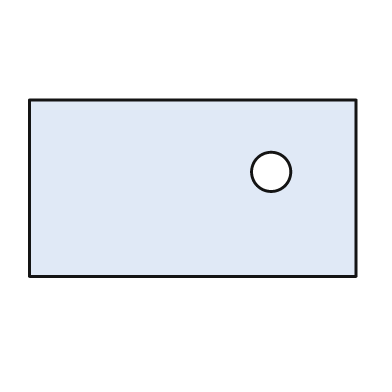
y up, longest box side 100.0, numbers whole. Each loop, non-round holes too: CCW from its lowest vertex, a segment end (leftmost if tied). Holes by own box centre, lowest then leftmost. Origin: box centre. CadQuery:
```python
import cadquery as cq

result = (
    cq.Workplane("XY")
    .moveTo(-50.0, -27.0)
    .lineTo(50.0, -27.0)
    .lineTo(50.0, 27.0)
    .lineTo(-50.0, 27.0)
    .close()
    .moveTo(24.0, 5.0)
    .circle(6.0)
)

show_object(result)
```